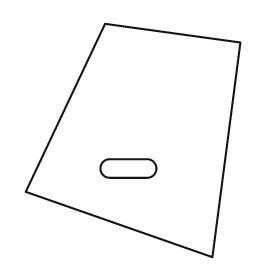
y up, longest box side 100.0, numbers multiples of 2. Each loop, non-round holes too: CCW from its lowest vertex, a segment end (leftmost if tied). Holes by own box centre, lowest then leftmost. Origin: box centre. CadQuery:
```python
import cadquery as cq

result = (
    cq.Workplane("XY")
    .moveTo(34.0, -50.0)
    .lineTo(46.0, 42.0)
    .lineTo(-12.0, 50.0)
    .lineTo(-46.0, -22.0)
    .close()
    .moveTo(-10.0, -16.0)
    .lineTo(6.0, -16.0)
    .threePointArc((10.0, -12.0), (6.0, -8.0))
    .lineTo(-10.0, -8.0)
    .threePointArc((-14.0, -12.0), (-10.0, -16.0))
    .close()
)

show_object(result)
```